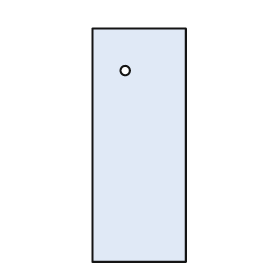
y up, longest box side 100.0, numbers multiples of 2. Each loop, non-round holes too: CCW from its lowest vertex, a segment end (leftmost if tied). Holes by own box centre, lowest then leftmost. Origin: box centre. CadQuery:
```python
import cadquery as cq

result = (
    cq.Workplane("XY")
    .moveTo(-20.0, -50.0)
    .lineTo(20.0, -50.0)
    .lineTo(20.0, 50.0)
    .lineTo(-20.0, 50.0)
    .close()
    .moveTo(-6.0, 32.0)
    .circle(2.0)
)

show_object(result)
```